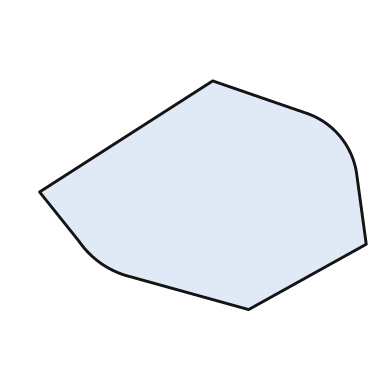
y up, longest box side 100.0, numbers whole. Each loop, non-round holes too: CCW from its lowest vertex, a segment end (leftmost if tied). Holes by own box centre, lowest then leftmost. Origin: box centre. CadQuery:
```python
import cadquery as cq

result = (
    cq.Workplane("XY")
    .moveTo(14.0, -35.0)
    .lineTo(50.0, -15.0)
    .lineTo(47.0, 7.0)
    .threePointArc((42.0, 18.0), (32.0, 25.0))
    .lineTo(3.0, 35.0)
    .lineTo(-50.0, 1.0)
    .lineTo(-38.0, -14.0)
    .threePointArc((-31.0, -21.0), (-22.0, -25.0))
    .close()
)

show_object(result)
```